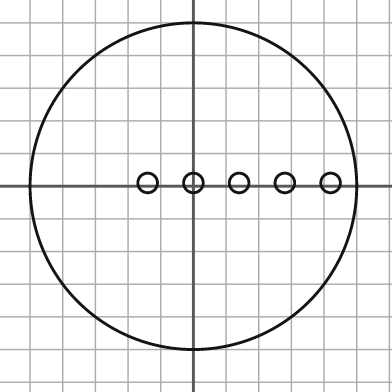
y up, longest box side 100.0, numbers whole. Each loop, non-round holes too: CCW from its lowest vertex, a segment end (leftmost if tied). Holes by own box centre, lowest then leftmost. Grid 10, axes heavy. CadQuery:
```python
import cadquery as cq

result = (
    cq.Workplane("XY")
    .moveTo(0.0, 0.0)
    .circle(50.0)
    .moveTo(-14.0, 1.0)
    .circle(3.0)
    .moveTo(0.0, 1.0)
    .circle(3.0)
    .moveTo(14.0, 1.0)
    .circle(3.0)
    .moveTo(28.0, 1.0)
    .circle(3.0)
    .moveTo(42.0, 1.0)
    .circle(3.0)
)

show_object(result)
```